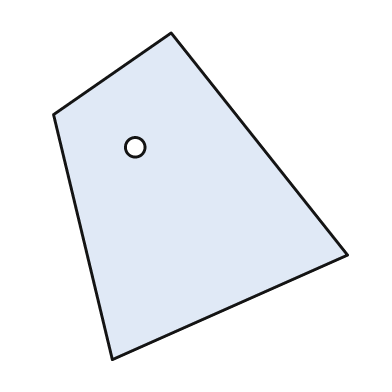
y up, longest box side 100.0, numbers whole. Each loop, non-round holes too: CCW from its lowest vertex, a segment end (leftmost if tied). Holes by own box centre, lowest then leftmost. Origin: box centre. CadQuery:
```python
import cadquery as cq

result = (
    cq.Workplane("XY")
    .moveTo(-27.0, -50.0)
    .lineTo(45.0, -18.0)
    .lineTo(-9.0, 50.0)
    .lineTo(-45.0, 25.0)
    .close()
    .moveTo(-20.0, 15.0)
    .circle(3.0)
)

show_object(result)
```